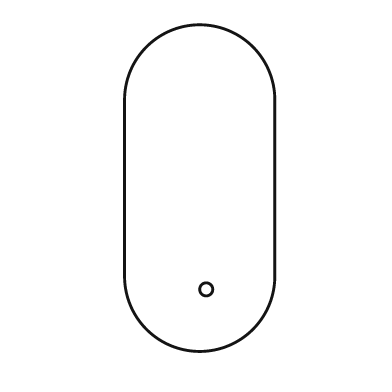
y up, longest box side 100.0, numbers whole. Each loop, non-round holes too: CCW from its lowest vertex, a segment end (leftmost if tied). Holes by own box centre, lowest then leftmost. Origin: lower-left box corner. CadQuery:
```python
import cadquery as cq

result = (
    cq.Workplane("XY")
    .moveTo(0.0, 23.0)
    .threePointArc((23.0, 0.0), (46.0, 23.0))
    .lineTo(46.0, 77.0)
    .threePointArc((23.0, 100.0), (0.0, 77.0))
    .close()
    .moveTo(25.0, 19.0)
    .circle(2.0)
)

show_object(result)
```